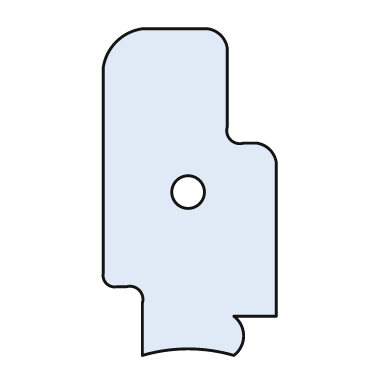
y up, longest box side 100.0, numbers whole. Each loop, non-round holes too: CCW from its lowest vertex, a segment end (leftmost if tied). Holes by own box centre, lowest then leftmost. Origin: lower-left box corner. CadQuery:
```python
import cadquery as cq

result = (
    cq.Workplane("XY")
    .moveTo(12.0, 0.0)
    .threePointArc((26.0, 2.0), (40.0, 0.0))
    .threePointArc((43.0, 6.0), (40.0, 12.0))
    .lineTo(53.0, 12.0)
    .lineTo(53.0, 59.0)
    .threePointArc((51.0, 63.0), (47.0, 65.0))
    .lineTo(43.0, 65.0)
    .threePointArc((39.0, 66.0), (38.0, 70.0))
    .lineTo(38.0, 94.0)
    .threePointArc((36.0, 98.0), (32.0, 100.0))
    .lineTo(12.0, 100.0)
    .threePointArc((4.0, 96.0), (0.0, 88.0))
    .lineTo(0.0, 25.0)
    .threePointArc((1.0, 22.0), (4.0, 21.0))
    .lineTo(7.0, 21.0)
    .threePointArc((11.0, 20.0), (12.0, 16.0))
    .close()
    .moveTo(26.0, 50.0)
    .circle(5.0)
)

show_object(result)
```